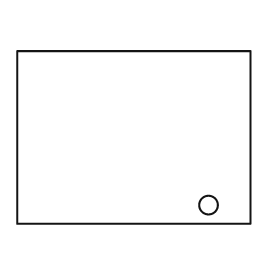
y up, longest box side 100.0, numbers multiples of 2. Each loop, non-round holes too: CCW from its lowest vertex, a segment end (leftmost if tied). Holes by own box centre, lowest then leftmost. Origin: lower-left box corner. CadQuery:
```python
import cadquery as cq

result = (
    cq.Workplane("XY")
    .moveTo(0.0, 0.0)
    .lineTo(100.0, 0.0)
    .lineTo(100.0, 74.0)
    .lineTo(0.0, 74.0)
    .close()
    .moveTo(82.0, 8.0)
    .circle(4.0)
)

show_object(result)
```